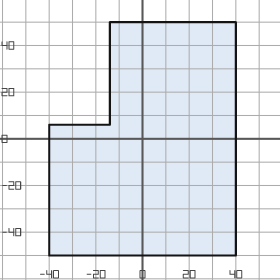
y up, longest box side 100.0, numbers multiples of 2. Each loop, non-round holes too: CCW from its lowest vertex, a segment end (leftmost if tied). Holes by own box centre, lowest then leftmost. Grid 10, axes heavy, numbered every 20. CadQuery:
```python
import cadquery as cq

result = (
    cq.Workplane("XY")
    .moveTo(-40.0, -50.0)
    .lineTo(40.0, -50.0)
    .lineTo(40.0, 50.0)
    .lineTo(-14.0, 50.0)
    .lineTo(-14.0, 6.0)
    .lineTo(-40.0, 6.0)
    .close()
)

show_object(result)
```